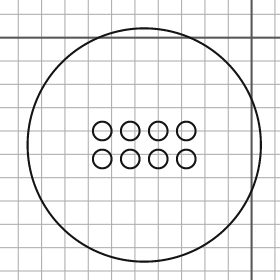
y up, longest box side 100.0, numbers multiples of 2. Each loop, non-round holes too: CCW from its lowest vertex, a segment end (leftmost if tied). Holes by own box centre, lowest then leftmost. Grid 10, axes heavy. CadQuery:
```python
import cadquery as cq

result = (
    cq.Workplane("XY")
    .moveTo(-46.0, -46.0)
    .circle(50.0)
    .moveTo(-64.0, -52.0)
    .circle(4.0)
    .moveTo(-52.0, -52.0)
    .circle(4.0)
    .moveTo(-40.0, -52.0)
    .circle(4.0)
    .moveTo(-28.0, -52.0)
    .circle(4.0)
    .moveTo(-64.0, -40.0)
    .circle(4.0)
    .moveTo(-52.0, -40.0)
    .circle(4.0)
    .moveTo(-40.0, -40.0)
    .circle(4.0)
    .moveTo(-28.0, -40.0)
    .circle(4.0)
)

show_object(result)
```